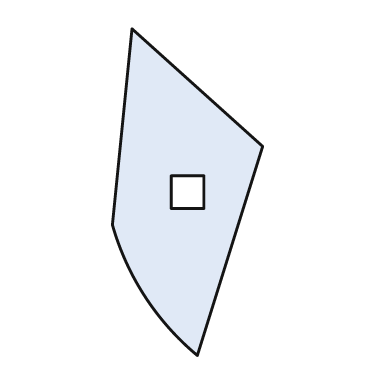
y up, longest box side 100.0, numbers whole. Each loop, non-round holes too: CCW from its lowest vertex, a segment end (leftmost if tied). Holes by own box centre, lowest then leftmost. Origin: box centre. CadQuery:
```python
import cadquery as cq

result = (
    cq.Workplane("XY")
    .moveTo(3.0, -50.0)
    .lineTo(23.0, 14.0)
    .lineTo(-17.0, 50.0)
    .lineTo(-23.0, -10.0)
    .threePointArc((-13.0, -32.0), (3.0, -50.0))
    .close()
    .moveTo(-5.0, -5.0)
    .lineTo(5.0, -5.0)
    .lineTo(5.0, 5.0)
    .lineTo(-5.0, 5.0)
    .close()
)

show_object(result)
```